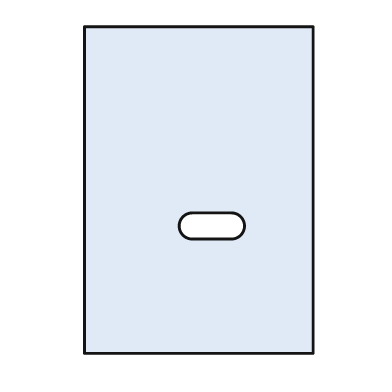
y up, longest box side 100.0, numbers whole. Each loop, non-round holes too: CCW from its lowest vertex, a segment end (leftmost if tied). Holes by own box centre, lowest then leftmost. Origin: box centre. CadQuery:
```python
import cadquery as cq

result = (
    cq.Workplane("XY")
    .moveTo(-35.0, -50.0)
    .lineTo(35.0, -50.0)
    .lineTo(35.0, 50.0)
    .lineTo(-35.0, 50.0)
    .close()
    .moveTo(-2.0, -15.0)
    .lineTo(10.0, -15.0)
    .threePointArc((14.0, -11.0), (10.0, -7.0))
    .lineTo(-2.0, -7.0)
    .threePointArc((-6.0, -11.0), (-2.0, -15.0))
    .close()
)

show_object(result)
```